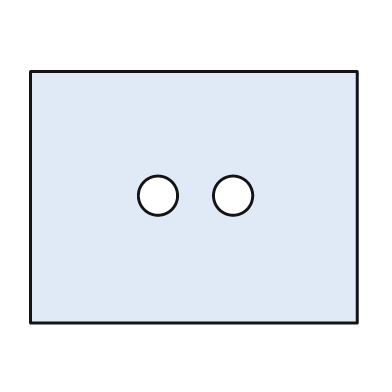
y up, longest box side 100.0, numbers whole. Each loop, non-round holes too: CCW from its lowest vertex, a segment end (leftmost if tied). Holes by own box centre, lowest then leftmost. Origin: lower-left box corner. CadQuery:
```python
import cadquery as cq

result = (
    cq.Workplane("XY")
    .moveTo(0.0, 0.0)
    .lineTo(100.0, 0.0)
    .lineTo(100.0, 77.0)
    .lineTo(0.0, 77.0)
    .close()
    .moveTo(39.0, 39.0)
    .circle(6.0)
    .moveTo(62.0, 39.0)
    .circle(6.0)
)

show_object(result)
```